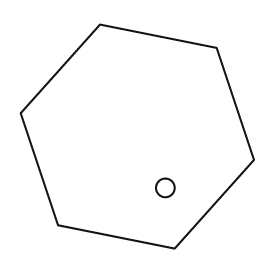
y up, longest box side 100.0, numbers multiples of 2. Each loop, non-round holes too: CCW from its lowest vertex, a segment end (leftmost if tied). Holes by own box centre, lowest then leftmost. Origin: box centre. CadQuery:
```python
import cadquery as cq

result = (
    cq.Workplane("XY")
    .moveTo(16.0, -48.0)
    .lineTo(50.0, -10.0)
    .lineTo(34.0, 38.0)
    .lineTo(-16.0, 48.0)
    .lineTo(-50.0, 10.0)
    .lineTo(-34.0, -38.0)
    .close()
    .moveTo(12.0, -22.0)
    .circle(4.0)
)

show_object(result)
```